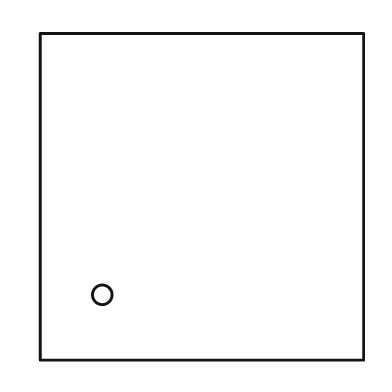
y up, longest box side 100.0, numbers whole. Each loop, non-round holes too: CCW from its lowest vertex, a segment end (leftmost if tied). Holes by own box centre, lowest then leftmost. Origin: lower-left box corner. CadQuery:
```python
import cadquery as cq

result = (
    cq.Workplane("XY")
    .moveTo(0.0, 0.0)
    .lineTo(99.0, 0.0)
    .lineTo(99.0, 100.0)
    .lineTo(0.0, 100.0)
    .close()
    .moveTo(19.0, 20.0)
    .circle(3.0)
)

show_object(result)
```